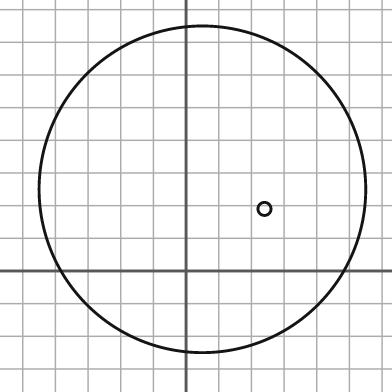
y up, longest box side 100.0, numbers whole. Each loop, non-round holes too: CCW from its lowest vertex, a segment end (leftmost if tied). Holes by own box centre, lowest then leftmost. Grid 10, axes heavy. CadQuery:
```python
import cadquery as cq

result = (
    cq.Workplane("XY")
    .moveTo(5.0, 25.0)
    .circle(50.0)
    .moveTo(24.0, 19.0)
    .circle(2.0)
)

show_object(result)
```